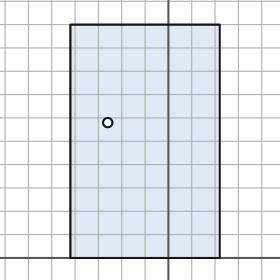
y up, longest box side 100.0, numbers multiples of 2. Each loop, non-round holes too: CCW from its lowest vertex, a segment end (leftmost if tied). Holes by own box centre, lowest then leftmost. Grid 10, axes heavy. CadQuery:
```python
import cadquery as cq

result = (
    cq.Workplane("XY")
    .moveTo(-42.0, 0.0)
    .lineTo(22.0, 0.0)
    .lineTo(22.0, 100.0)
    .lineTo(-42.0, 100.0)
    .close()
    .moveTo(-26.0, 58.0)
    .circle(2.0)
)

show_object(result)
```